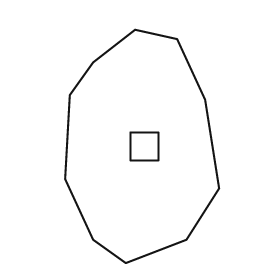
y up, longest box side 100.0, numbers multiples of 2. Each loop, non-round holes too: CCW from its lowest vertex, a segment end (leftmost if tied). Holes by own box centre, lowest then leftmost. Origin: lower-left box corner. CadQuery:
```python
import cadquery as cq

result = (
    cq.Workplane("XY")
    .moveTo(26.0, 0.0)
    .lineTo(52.0, 10.0)
    .lineTo(66.0, 32.0)
    .lineTo(60.0, 70.0)
    .lineTo(48.0, 96.0)
    .lineTo(30.0, 100.0)
    .lineTo(12.0, 86.0)
    .lineTo(2.0, 72.0)
    .lineTo(0.0, 36.0)
    .lineTo(12.0, 10.0)
    .close()
    .moveTo(28.0, 44.0)
    .lineTo(40.0, 44.0)
    .lineTo(40.0, 56.0)
    .lineTo(28.0, 56.0)
    .close()
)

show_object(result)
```